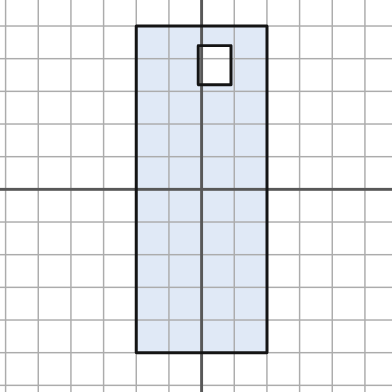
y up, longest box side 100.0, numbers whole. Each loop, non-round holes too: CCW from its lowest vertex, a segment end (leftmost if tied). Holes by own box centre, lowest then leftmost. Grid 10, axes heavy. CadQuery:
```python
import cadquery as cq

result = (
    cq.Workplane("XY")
    .moveTo(-20.0, -50.0)
    .lineTo(20.0, -50.0)
    .lineTo(20.0, 50.0)
    .lineTo(-20.0, 50.0)
    .close()
    .moveTo(-1.0, 32.0)
    .lineTo(9.0, 32.0)
    .lineTo(9.0, 44.0)
    .lineTo(-1.0, 44.0)
    .close()
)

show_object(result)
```